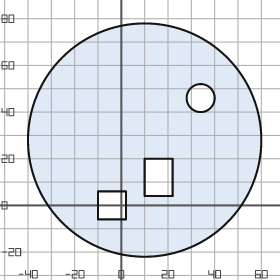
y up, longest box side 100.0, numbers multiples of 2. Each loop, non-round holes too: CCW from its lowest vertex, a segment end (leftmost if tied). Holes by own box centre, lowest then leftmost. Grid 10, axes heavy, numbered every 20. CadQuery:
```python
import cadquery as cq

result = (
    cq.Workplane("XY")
    .moveTo(10.0, 28.0)
    .circle(50.0)
    .moveTo(-10.0, -6.0)
    .lineTo(2.0, -6.0)
    .lineTo(2.0, 6.0)
    .lineTo(-10.0, 6.0)
    .close()
    .moveTo(10.0, 4.0)
    .lineTo(22.0, 4.0)
    .lineTo(22.0, 20.0)
    .lineTo(10.0, 20.0)
    .close()
    .moveTo(34.0, 46.0)
    .circle(6.0)
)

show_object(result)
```